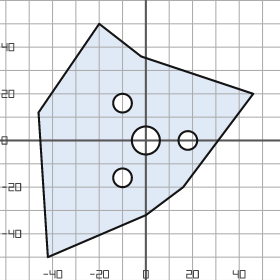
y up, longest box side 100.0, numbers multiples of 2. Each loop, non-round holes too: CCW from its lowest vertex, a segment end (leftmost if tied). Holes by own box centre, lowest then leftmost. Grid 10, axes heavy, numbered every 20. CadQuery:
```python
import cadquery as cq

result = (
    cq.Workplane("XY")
    .moveTo(-42.0, -50.0)
    .lineTo(0.0, -32.0)
    .lineTo(16.0, -20.0)
    .lineTo(46.0, 20.0)
    .lineTo(-2.0, 36.0)
    .lineTo(-20.0, 50.0)
    .lineTo(-46.0, 12.0)
    .close()
    .moveTo(-10.0, -16.0)
    .circle(4.0)
    .moveTo(0.0, 0.0)
    .circle(6.0)
    .moveTo(18.0, 0.0)
    .circle(4.0)
    .moveTo(-10.0, 16.0)
    .circle(4.0)
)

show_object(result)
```